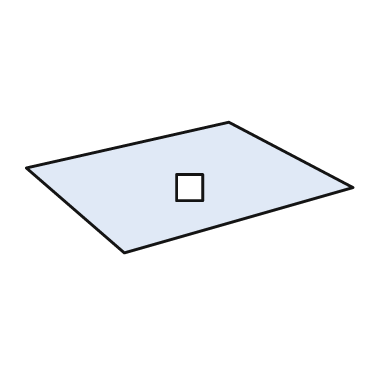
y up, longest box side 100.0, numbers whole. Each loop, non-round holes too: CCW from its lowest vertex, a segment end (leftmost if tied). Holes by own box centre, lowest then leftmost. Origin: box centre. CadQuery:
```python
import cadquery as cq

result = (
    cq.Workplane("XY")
    .moveTo(-20.0, -20.0)
    .lineTo(50.0, 0.0)
    .lineTo(12.0, 20.0)
    .lineTo(-50.0, 6.0)
    .close()
    .moveTo(-4.0, -4.0)
    .lineTo(4.0, -4.0)
    .lineTo(4.0, 4.0)
    .lineTo(-4.0, 4.0)
    .close()
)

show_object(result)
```